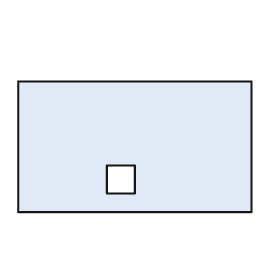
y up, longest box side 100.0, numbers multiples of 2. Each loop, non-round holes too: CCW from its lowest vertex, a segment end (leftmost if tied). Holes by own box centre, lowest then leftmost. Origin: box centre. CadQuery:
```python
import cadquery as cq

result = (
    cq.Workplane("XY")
    .moveTo(-50.0, -28.0)
    .lineTo(50.0, -28.0)
    .lineTo(50.0, 28.0)
    .lineTo(-50.0, 28.0)
    .close()
    .moveTo(-12.0, -20.0)
    .lineTo(0.0, -20.0)
    .lineTo(0.0, -8.0)
    .lineTo(-12.0, -8.0)
    .close()
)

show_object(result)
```